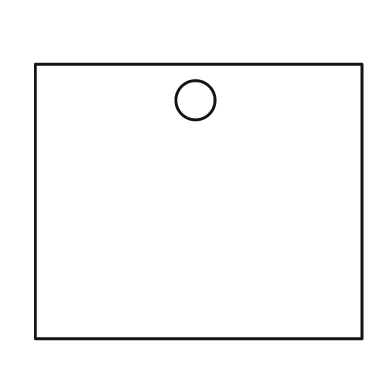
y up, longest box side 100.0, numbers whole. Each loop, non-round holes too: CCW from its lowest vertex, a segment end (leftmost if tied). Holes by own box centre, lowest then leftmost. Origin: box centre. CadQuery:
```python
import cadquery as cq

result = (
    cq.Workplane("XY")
    .moveTo(-50.0, -42.0)
    .lineTo(50.0, -42.0)
    .lineTo(50.0, 42.0)
    .lineTo(-50.0, 42.0)
    .close()
    .moveTo(-1.0, 31.0)
    .circle(6.0)
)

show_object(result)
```